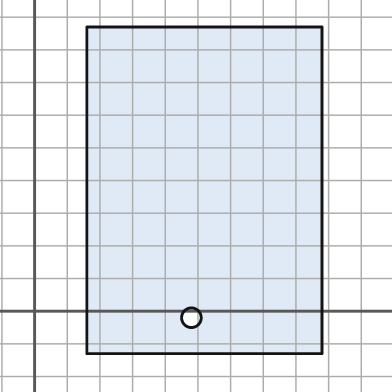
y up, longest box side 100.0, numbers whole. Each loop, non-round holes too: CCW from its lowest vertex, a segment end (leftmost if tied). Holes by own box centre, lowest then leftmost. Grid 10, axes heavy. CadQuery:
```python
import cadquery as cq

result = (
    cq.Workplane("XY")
    .moveTo(16.0, -13.0)
    .lineTo(88.0, -13.0)
    .lineTo(88.0, 87.0)
    .lineTo(16.0, 87.0)
    .close()
    .moveTo(48.0, -2.0)
    .circle(3.0)
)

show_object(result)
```